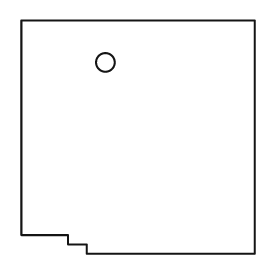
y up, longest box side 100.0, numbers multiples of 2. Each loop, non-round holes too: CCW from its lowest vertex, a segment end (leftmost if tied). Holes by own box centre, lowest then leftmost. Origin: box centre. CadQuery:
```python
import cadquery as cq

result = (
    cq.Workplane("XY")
    .moveTo(-22.0, -50.0)
    .lineTo(50.0, -50.0)
    .lineTo(50.0, 50.0)
    .lineTo(-50.0, 50.0)
    .lineTo(-50.0, -42.0)
    .lineTo(-30.0, -42.0)
    .lineTo(-30.0, -46.0)
    .lineTo(-22.0, -46.0)
    .close()
    .moveTo(-14.0, 32.0)
    .circle(4.0)
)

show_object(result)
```